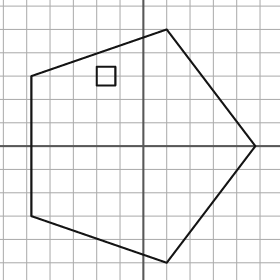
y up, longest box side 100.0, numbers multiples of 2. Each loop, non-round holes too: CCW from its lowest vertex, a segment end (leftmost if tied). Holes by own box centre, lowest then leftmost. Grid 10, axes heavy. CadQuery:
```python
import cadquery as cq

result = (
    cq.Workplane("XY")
    .moveTo(10.0, -50.0)
    .lineTo(48.0, 0.0)
    .lineTo(10.0, 50.0)
    .lineTo(-48.0, 30.0)
    .lineTo(-48.0, -30.0)
    .close()
    .moveTo(-20.0, 26.0)
    .lineTo(-12.0, 26.0)
    .lineTo(-12.0, 34.0)
    .lineTo(-20.0, 34.0)
    .close()
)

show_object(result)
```